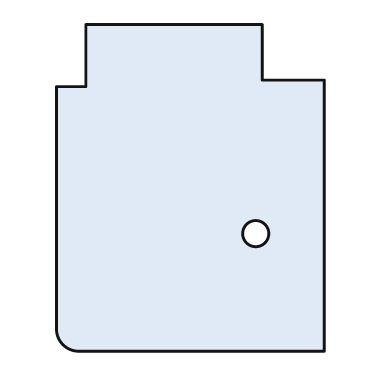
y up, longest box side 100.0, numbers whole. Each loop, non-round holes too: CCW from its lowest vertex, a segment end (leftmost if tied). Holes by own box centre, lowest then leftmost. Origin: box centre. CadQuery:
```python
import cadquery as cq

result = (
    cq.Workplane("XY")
    .moveTo(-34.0, -50.0)
    .lineTo(41.0, -50.0)
    .lineTo(41.0, 33.0)
    .lineTo(22.0, 33.0)
    .lineTo(22.0, 50.0)
    .lineTo(-32.0, 50.0)
    .lineTo(-32.0, 31.0)
    .lineTo(-41.0, 31.0)
    .lineTo(-41.0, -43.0)
    .threePointArc((-39.0, -48.0), (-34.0, -50.0))
    .close()
    .moveTo(20.0, -14.0)
    .circle(4.0)
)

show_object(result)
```